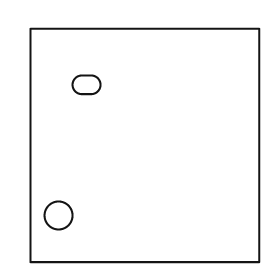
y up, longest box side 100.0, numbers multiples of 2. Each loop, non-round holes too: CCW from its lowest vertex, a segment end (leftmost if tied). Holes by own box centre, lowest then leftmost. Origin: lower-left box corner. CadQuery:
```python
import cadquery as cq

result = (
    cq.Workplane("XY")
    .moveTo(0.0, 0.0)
    .lineTo(98.0, 0.0)
    .lineTo(98.0, 100.0)
    .lineTo(0.0, 100.0)
    .close()
    .moveTo(12.0, 20.0)
    .circle(6.0)
    .moveTo(22.0, 72.0)
    .lineTo(26.0, 72.0)
    .threePointArc((30.0, 76.0), (26.0, 80.0))
    .lineTo(22.0, 80.0)
    .threePointArc((18.0, 76.0), (22.0, 72.0))
    .close()
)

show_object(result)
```